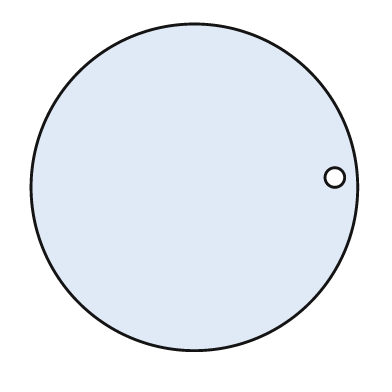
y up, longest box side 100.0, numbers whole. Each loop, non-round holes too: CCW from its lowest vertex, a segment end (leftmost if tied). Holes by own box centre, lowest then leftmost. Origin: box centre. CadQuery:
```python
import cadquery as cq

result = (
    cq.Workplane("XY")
    .moveTo(0.0, 0.0)
    .circle(50.0)
    .moveTo(43.0, 3.0)
    .circle(3.0)
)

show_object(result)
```